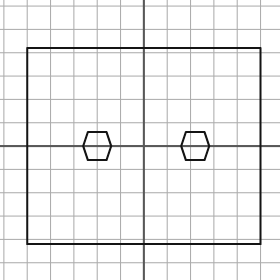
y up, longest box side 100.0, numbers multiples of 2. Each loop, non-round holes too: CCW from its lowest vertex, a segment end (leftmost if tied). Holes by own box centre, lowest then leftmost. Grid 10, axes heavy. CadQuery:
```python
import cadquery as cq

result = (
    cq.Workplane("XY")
    .moveTo(-50.0, -42.0)
    .lineTo(50.0, -42.0)
    .lineTo(50.0, 42.0)
    .lineTo(-50.0, 42.0)
    .close()
    .moveTo(-24.0, -6.0)
    .lineTo(-16.0, -6.0)
    .lineTo(-14.0, 0.0)
    .lineTo(-16.0, 6.0)
    .lineTo(-24.0, 6.0)
    .lineTo(-26.0, 0.0)
    .close()
    .moveTo(18.0, -6.0)
    .lineTo(26.0, -6.0)
    .lineTo(28.0, 0.0)
    .lineTo(26.0, 6.0)
    .lineTo(18.0, 6.0)
    .lineTo(16.0, 0.0)
    .close()
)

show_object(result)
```